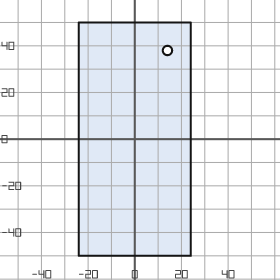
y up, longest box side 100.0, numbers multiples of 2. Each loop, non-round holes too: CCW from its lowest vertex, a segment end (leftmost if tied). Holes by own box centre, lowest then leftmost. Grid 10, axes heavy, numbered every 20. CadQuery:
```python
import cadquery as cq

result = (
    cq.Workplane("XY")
    .moveTo(-24.0, -50.0)
    .lineTo(24.0, -50.0)
    .lineTo(24.0, 50.0)
    .lineTo(-24.0, 50.0)
    .close()
    .moveTo(14.0, 38.0)
    .circle(2.0)
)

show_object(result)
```